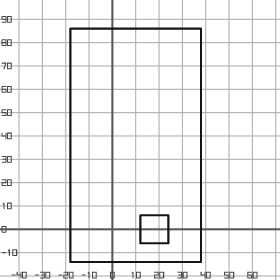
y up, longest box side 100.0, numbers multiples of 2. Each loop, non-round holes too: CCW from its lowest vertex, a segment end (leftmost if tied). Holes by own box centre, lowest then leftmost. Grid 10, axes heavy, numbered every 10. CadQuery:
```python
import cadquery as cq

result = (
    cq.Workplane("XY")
    .moveTo(-18.0, -14.0)
    .lineTo(38.0, -14.0)
    .lineTo(38.0, 86.0)
    .lineTo(-18.0, 86.0)
    .close()
    .moveTo(12.0, -6.0)
    .lineTo(24.0, -6.0)
    .lineTo(24.0, 6.0)
    .lineTo(12.0, 6.0)
    .close()
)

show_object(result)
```